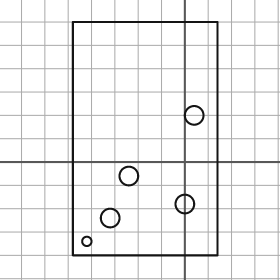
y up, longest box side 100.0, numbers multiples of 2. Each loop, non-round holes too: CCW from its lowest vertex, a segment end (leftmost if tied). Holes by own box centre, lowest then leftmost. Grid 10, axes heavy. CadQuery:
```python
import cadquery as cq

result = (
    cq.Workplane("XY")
    .moveTo(-48.0, -40.0)
    .lineTo(14.0, -40.0)
    .lineTo(14.0, 60.0)
    .lineTo(-48.0, 60.0)
    .close()
    .moveTo(-42.0, -34.0)
    .circle(2.0)
    .moveTo(-32.0, -24.0)
    .circle(4.0)
    .moveTo(0.0, -18.0)
    .circle(4.0)
    .moveTo(-24.0, -6.0)
    .circle(4.0)
    .moveTo(4.0, 20.0)
    .circle(4.0)
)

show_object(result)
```